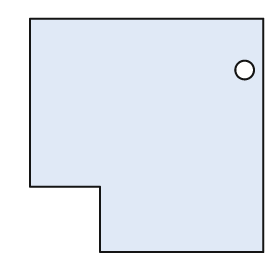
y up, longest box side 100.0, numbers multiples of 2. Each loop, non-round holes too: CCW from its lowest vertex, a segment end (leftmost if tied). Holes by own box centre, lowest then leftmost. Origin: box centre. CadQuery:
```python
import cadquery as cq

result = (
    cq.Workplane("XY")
    .moveTo(-20.0, -50.0)
    .lineTo(50.0, -50.0)
    .lineTo(50.0, 50.0)
    .lineTo(-50.0, 50.0)
    .lineTo(-50.0, -22.0)
    .lineTo(-20.0, -22.0)
    .close()
    .moveTo(42.0, 28.0)
    .circle(4.0)
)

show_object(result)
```